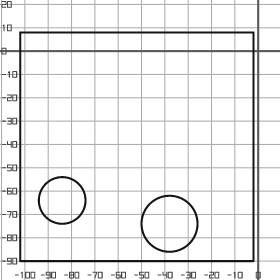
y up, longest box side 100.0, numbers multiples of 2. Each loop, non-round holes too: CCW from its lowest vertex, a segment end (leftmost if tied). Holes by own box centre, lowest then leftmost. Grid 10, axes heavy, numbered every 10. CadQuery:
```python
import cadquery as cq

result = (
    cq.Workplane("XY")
    .moveTo(-102.0, -90.0)
    .lineTo(-2.0, -90.0)
    .lineTo(-2.0, 8.0)
    .lineTo(-102.0, 8.0)
    .close()
    .moveTo(-38.0, -74.0)
    .circle(12.0)
    .moveTo(-84.0, -64.0)
    .circle(10.0)
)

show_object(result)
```